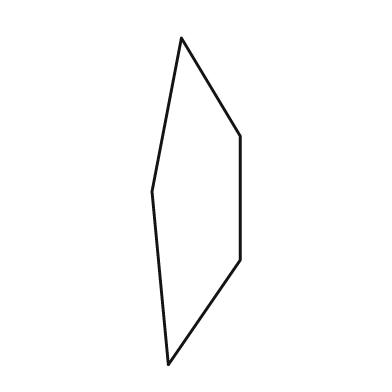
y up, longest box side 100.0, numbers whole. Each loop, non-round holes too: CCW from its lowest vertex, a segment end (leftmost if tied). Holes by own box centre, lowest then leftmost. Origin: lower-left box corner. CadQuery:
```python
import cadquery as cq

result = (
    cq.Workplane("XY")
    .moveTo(5.0, 0.0)
    .lineTo(27.0, 32.0)
    .lineTo(27.0, 70.0)
    .lineTo(9.0, 100.0)
    .lineTo(0.0, 53.0)
    .close()
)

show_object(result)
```